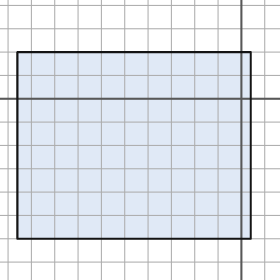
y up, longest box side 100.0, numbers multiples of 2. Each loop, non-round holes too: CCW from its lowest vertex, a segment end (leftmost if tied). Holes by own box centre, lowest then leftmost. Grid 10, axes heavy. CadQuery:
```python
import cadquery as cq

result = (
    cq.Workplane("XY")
    .moveTo(-96.0, -60.0)
    .lineTo(4.0, -60.0)
    .lineTo(4.0, 20.0)
    .lineTo(-96.0, 20.0)
    .close()
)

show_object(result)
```